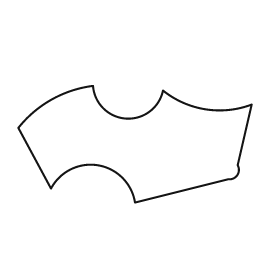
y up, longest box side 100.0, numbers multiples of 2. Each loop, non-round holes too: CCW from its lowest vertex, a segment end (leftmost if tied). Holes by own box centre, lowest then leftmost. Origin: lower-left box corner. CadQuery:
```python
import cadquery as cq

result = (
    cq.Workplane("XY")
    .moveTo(50.0, 0.0)
    .lineTo(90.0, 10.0)
    .threePointArc((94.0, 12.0), (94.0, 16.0))
    .lineTo(100.0, 42.0)
    .threePointArc((80.0, 40.0), (62.0, 48.0))
    .threePointArc((46.0, 36.0), (32.0, 50.0))
    .threePointArc((14.0, 44.0), (0.0, 32.0))
    .lineTo(14.0, 6.0)
    .threePointArc((34.0, 16.0), (50.0, 0.0))
    .close()
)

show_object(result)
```